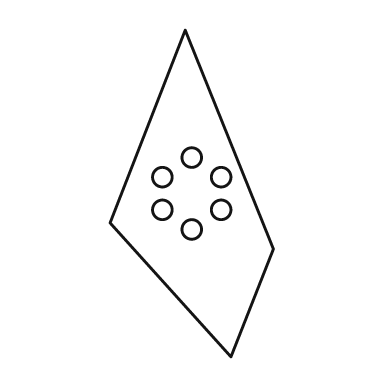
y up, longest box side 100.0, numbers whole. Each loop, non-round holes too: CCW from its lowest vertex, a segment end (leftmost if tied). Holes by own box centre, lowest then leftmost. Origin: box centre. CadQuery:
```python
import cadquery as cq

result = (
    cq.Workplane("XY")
    .moveTo(12.0, -50.0)
    .lineTo(25.0, -17.0)
    .lineTo(-2.0, 50.0)
    .lineTo(-25.0, -9.0)
    .close()
    .moveTo(0.0, -11.0)
    .circle(3.0)
    .moveTo(-9.0, -5.0)
    .circle(3.0)
    .moveTo(9.0, -5.0)
    .circle(3.0)
    .moveTo(-9.0, 5.0)
    .circle(3.0)
    .moveTo(9.0, 5.0)
    .circle(3.0)
    .moveTo(0.0, 11.0)
    .circle(3.0)
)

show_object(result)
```